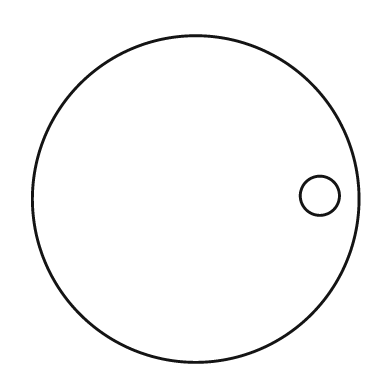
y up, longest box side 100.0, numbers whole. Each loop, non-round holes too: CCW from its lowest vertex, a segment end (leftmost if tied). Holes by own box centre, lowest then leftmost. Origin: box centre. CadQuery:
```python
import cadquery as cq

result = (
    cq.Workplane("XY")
    .moveTo(0.0, 0.0)
    .circle(50.0)
    .moveTo(38.0, 1.0)
    .circle(6.0)
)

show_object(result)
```